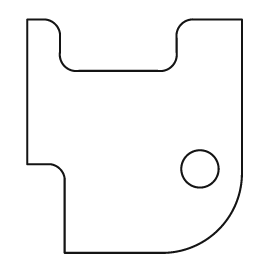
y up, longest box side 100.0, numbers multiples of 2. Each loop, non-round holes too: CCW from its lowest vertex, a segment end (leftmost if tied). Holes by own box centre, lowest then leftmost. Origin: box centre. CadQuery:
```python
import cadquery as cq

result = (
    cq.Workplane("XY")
    .moveTo(-30.0, -50.0)
    .lineTo(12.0, -50.0)
    .threePointArc((36.0, -40.0), (46.0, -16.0))
    .lineTo(46.0, 50.0)
    .lineTo(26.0, 50.0)
    .threePointArc((20.0, 48.0), (18.0, 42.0))
    .lineTo(18.0, 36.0)
    .threePointArc((16.0, 30.0), (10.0, 28.0))
    .lineTo(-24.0, 28.0)
    .threePointArc((-30.0, 30.0), (-32.0, 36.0))
    .lineTo(-32.0, 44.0)
    .threePointArc((-34.0, 48.0), (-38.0, 50.0))
    .lineTo(-46.0, 50.0)
    .lineTo(-46.0, -12.0)
    .lineTo(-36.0, -12.0)
    .threePointArc((-32.0, -14.0), (-30.0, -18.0))
    .close()
    .moveTo(28.0, -14.0)
    .circle(8.0)
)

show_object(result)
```